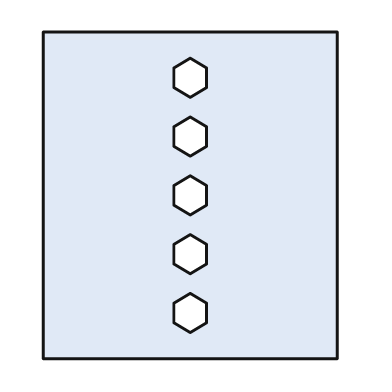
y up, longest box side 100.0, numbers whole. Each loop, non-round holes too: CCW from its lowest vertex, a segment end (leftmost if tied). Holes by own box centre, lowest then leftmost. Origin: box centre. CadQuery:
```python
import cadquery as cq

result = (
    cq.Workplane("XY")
    .moveTo(-45.0, -50.0)
    .lineTo(45.0, -50.0)
    .lineTo(45.0, 50.0)
    .lineTo(-45.0, 50.0)
    .close()
    .moveTo(0.0, -42.0)
    .lineTo(5.0, -39.0)
    .lineTo(5.0, -33.0)
    .lineTo(0.0, -30.0)
    .lineTo(-5.0, -33.0)
    .lineTo(-5.0, -39.0)
    .close()
    .moveTo(0.0, -24.0)
    .lineTo(5.0, -21.0)
    .lineTo(5.0, -15.0)
    .lineTo(0.0, -12.0)
    .lineTo(-5.0, -15.0)
    .lineTo(-5.0, -21.0)
    .close()
    .moveTo(0.0, -6.0)
    .lineTo(5.0, -3.0)
    .lineTo(5.0, 3.0)
    .lineTo(0.0, 6.0)
    .lineTo(-5.0, 3.0)
    .lineTo(-5.0, -3.0)
    .close()
    .moveTo(0.0, 12.0)
    .lineTo(5.0, 15.0)
    .lineTo(5.0, 21.0)
    .lineTo(0.0, 24.0)
    .lineTo(-5.0, 21.0)
    .lineTo(-5.0, 15.0)
    .close()
    .moveTo(0.0, 30.0)
    .lineTo(5.0, 33.0)
    .lineTo(5.0, 39.0)
    .lineTo(0.0, 42.0)
    .lineTo(-5.0, 39.0)
    .lineTo(-5.0, 33.0)
    .close()
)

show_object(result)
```